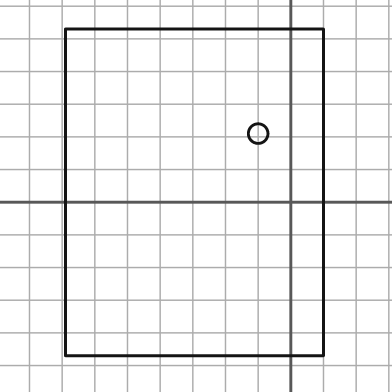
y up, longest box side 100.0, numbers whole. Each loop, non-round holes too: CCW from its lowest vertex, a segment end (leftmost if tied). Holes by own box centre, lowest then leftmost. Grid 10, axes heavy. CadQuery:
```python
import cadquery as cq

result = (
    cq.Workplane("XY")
    .moveTo(-69.0, -47.0)
    .lineTo(10.0, -47.0)
    .lineTo(10.0, 53.0)
    .lineTo(-69.0, 53.0)
    .close()
    .moveTo(-10.0, 21.0)
    .circle(3.0)
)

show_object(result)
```